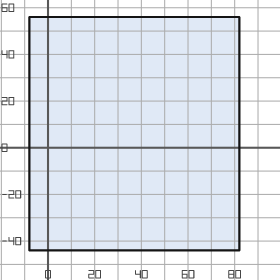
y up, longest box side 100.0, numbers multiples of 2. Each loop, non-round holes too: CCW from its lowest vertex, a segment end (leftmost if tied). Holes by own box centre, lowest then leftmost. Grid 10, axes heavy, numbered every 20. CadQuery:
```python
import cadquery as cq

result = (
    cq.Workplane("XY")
    .moveTo(-8.0, -44.0)
    .lineTo(82.0, -44.0)
    .lineTo(82.0, 56.0)
    .lineTo(-8.0, 56.0)
    .close()
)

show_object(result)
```